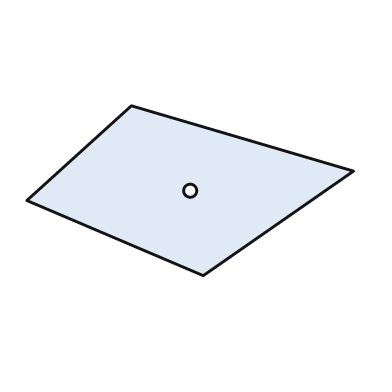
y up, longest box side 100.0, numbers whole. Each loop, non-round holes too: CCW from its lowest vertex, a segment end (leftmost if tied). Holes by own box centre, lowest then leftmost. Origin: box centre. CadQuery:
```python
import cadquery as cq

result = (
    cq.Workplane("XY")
    .moveTo(4.0, -26.0)
    .lineTo(50.0, 6.0)
    .lineTo(-18.0, 26.0)
    .lineTo(-50.0, -3.0)
    .close()
    .moveTo(0.0, 0.0)
    .circle(2.0)
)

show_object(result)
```